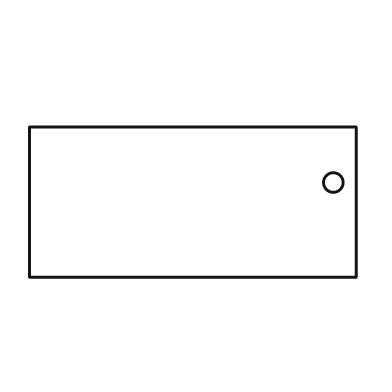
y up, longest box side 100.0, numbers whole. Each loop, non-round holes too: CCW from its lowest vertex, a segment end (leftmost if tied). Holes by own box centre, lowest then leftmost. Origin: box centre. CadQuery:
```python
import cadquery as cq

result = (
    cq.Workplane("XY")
    .moveTo(-50.0, -23.0)
    .lineTo(50.0, -23.0)
    .lineTo(50.0, 23.0)
    .lineTo(-50.0, 23.0)
    .close()
    .moveTo(43.0, 6.0)
    .circle(3.0)
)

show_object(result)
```